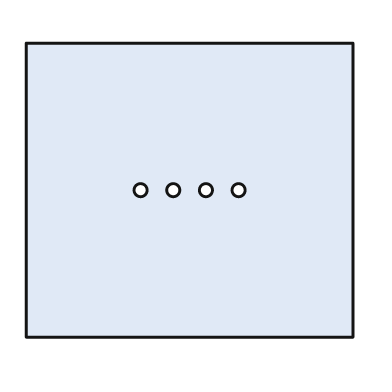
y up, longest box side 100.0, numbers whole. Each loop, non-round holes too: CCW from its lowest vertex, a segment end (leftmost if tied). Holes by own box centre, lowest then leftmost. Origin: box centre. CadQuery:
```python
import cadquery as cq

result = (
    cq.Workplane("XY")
    .moveTo(-50.0, -45.0)
    .lineTo(50.0, -45.0)
    .lineTo(50.0, 45.0)
    .lineTo(-50.0, 45.0)
    .close()
    .moveTo(-15.0, 0.0)
    .circle(2.0)
    .moveTo(-5.0, 0.0)
    .circle(2.0)
    .moveTo(5.0, 0.0)
    .circle(2.0)
    .moveTo(15.0, 0.0)
    .circle(2.0)
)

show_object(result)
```